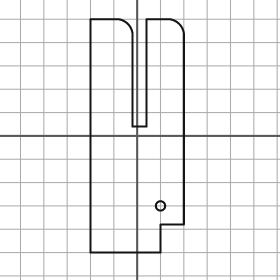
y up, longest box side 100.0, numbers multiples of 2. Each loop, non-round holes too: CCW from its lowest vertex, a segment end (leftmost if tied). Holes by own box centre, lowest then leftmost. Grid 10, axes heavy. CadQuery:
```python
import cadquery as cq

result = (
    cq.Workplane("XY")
    .moveTo(-20.0, -50.0)
    .lineTo(10.0, -50.0)
    .lineTo(10.0, -38.0)
    .lineTo(20.0, -38.0)
    .lineTo(20.0, 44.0)
    .threePointArc((18.0, 48.0), (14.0, 50.0))
    .lineTo(4.0, 50.0)
    .lineTo(4.0, 4.0)
    .lineTo(-2.0, 4.0)
    .lineTo(-2.0, 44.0)
    .threePointArc((-4.0, 48.0), (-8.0, 50.0))
    .lineTo(-20.0, 50.0)
    .close()
    .moveTo(10.0, -30.0)
    .circle(2.0)
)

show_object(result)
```